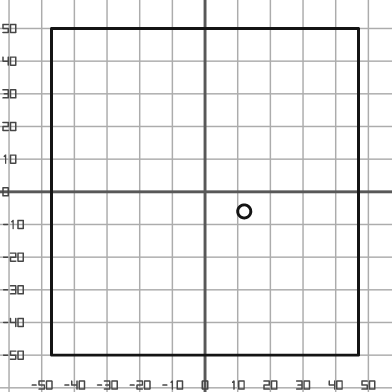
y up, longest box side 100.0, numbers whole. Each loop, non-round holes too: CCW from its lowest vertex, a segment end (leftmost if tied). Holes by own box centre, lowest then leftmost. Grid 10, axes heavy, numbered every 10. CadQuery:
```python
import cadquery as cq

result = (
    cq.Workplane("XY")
    .moveTo(-47.0, -50.0)
    .lineTo(47.0, -50.0)
    .lineTo(47.0, 50.0)
    .lineTo(-47.0, 50.0)
    .close()
    .moveTo(12.0, -6.0)
    .circle(2.0)
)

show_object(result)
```